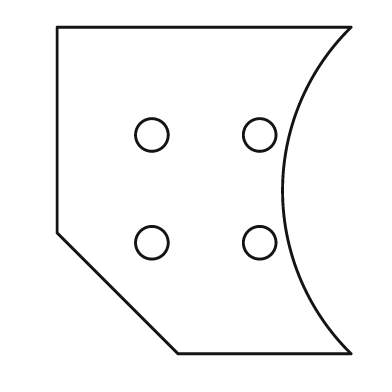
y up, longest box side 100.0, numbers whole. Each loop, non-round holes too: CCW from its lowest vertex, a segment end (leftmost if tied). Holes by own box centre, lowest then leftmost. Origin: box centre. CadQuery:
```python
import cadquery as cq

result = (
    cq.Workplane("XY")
    .moveTo(-8.0, -50.0)
    .lineTo(45.0, -50.0)
    .threePointArc((24.0, 0.0), (45.0, 50.0))
    .lineTo(-45.0, 50.0)
    .lineTo(-45.0, -13.0)
    .close()
    .moveTo(-16.0, -16.0)
    .circle(5.0)
    .moveTo(17.0, -16.0)
    .circle(5.0)
    .moveTo(-16.0, 17.0)
    .circle(5.0)
    .moveTo(17.0, 17.0)
    .circle(5.0)
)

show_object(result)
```